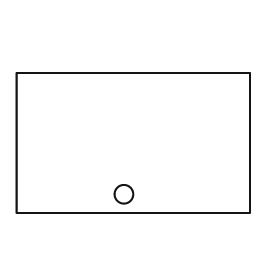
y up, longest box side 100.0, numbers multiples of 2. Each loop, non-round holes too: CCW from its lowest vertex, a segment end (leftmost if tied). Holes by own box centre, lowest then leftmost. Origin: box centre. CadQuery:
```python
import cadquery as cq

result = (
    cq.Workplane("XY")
    .moveTo(-50.0, -30.0)
    .lineTo(50.0, -30.0)
    .lineTo(50.0, 30.0)
    .lineTo(-50.0, 30.0)
    .close()
    .moveTo(-4.0, -22.0)
    .circle(4.0)
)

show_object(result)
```